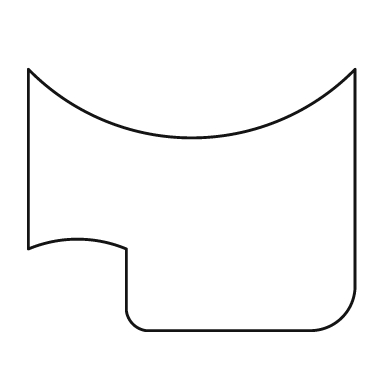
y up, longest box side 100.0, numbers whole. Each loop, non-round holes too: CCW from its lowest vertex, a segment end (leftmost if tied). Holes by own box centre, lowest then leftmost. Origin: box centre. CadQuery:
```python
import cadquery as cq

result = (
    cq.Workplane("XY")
    .moveTo(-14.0, -40.0)
    .lineTo(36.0, -40.0)
    .threePointArc((46.0, -36.0), (50.0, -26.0))
    .lineTo(50.0, 40.0)
    .threePointArc((0.0, 19.0), (-50.0, 40.0))
    .lineTo(-50.0, -15.0)
    .threePointArc((-35.0, -12.0), (-20.0, -15.0))
    .lineTo(-20.0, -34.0)
    .threePointArc((-18.0, -38.0), (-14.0, -40.0))
    .close()
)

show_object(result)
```